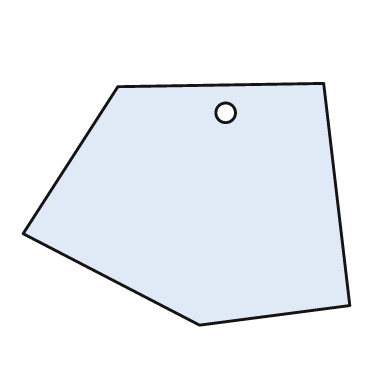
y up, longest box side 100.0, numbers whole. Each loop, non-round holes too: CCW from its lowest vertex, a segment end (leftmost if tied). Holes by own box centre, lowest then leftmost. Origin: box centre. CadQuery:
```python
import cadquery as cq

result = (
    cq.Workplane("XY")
    .moveTo(4.0, -37.0)
    .lineTo(50.0, -31.0)
    .lineTo(42.0, 37.0)
    .lineTo(-21.0, 36.0)
    .lineTo(-50.0, -9.0)
    .close()
    .moveTo(12.0, 28.0)
    .circle(3.0)
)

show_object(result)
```